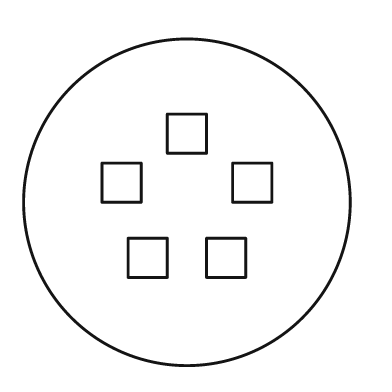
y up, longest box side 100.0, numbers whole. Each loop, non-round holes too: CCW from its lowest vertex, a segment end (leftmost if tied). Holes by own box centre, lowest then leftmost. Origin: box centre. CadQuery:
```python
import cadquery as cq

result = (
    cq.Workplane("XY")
    .moveTo(0.0, 0.0)
    .circle(50.0)
    .moveTo(-18.0, -23.0)
    .lineTo(-6.0, -23.0)
    .lineTo(-6.0, -11.0)
    .lineTo(-18.0, -11.0)
    .close()
    .moveTo(6.0, -23.0)
    .lineTo(18.0, -23.0)
    .lineTo(18.0, -11.0)
    .lineTo(6.0, -11.0)
    .close()
    .moveTo(-26.0, 0.0)
    .lineTo(-14.0, 0.0)
    .lineTo(-14.0, 12.0)
    .lineTo(-26.0, 12.0)
    .close()
    .moveTo(14.0, 0.0)
    .lineTo(26.0, 0.0)
    .lineTo(26.0, 12.0)
    .lineTo(14.0, 12.0)
    .close()
    .moveTo(-6.0, 15.0)
    .lineTo(6.0, 15.0)
    .lineTo(6.0, 27.0)
    .lineTo(-6.0, 27.0)
    .close()
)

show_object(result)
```